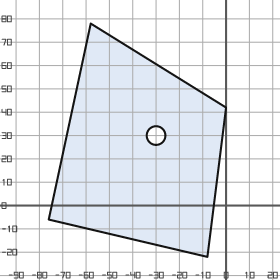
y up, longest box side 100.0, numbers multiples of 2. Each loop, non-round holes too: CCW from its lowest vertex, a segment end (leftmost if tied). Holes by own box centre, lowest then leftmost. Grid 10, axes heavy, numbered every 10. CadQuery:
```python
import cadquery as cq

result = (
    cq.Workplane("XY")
    .moveTo(-8.0, -22.0)
    .lineTo(0.0, 42.0)
    .lineTo(-58.0, 78.0)
    .lineTo(-76.0, -6.0)
    .close()
    .moveTo(-30.0, 30.0)
    .circle(4.0)
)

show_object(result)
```